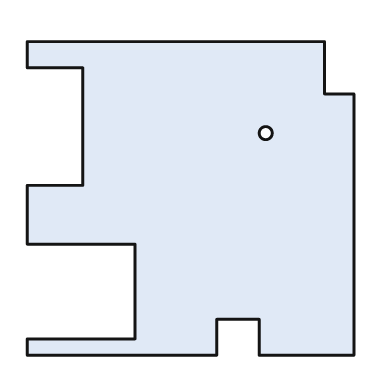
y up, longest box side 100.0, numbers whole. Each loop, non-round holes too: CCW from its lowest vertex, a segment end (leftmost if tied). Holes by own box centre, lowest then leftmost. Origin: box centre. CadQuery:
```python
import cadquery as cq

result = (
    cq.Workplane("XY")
    .moveTo(-50.0, -48.0)
    .lineTo(8.0, -48.0)
    .lineTo(8.0, -37.0)
    .lineTo(21.0, -37.0)
    .lineTo(21.0, -48.0)
    .lineTo(50.0, -48.0)
    .lineTo(50.0, 32.0)
    .lineTo(41.0, 32.0)
    .lineTo(41.0, 48.0)
    .lineTo(-50.0, 48.0)
    .lineTo(-50.0, 40.0)
    .lineTo(-33.0, 40.0)
    .lineTo(-33.0, 4.0)
    .lineTo(-50.0, 4.0)
    .lineTo(-50.0, -14.0)
    .lineTo(-17.0, -14.0)
    .lineTo(-17.0, -43.0)
    .lineTo(-50.0, -43.0)
    .close()
    .moveTo(23.0, 20.0)
    .circle(2.0)
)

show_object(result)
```